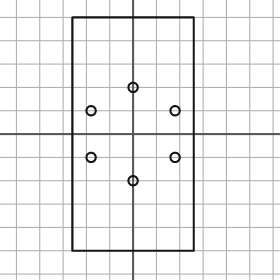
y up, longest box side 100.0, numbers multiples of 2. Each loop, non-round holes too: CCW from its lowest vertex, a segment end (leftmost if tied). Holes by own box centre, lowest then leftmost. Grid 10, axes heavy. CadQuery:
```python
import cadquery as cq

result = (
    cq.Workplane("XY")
    .moveTo(-26.0, -50.0)
    .lineTo(26.0, -50.0)
    .lineTo(26.0, 50.0)
    .lineTo(-26.0, 50.0)
    .close()
    .moveTo(0.0, -20.0)
    .circle(2.0)
    .moveTo(-18.0, -10.0)
    .circle(2.0)
    .moveTo(18.0, -10.0)
    .circle(2.0)
    .moveTo(-18.0, 10.0)
    .circle(2.0)
    .moveTo(18.0, 10.0)
    .circle(2.0)
    .moveTo(0.0, 20.0)
    .circle(2.0)
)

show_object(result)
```